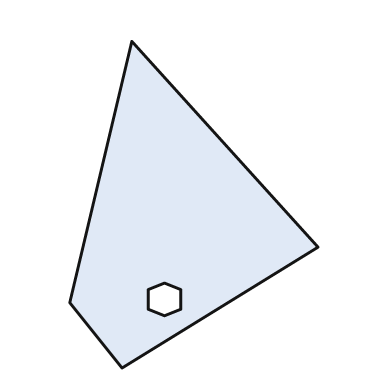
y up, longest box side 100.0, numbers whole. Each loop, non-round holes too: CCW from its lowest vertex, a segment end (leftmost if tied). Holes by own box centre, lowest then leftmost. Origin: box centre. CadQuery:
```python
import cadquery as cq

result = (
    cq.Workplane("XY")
    .moveTo(-22.0, -50.0)
    .lineTo(38.0, -13.0)
    .lineTo(-19.0, 50.0)
    .lineTo(-38.0, -30.0)
    .close()
    .moveTo(-9.0, -34.0)
    .lineTo(-4.0, -32.0)
    .lineTo(-4.0, -26.0)
    .lineTo(-9.0, -24.0)
    .lineTo(-14.0, -26.0)
    .lineTo(-14.0, -32.0)
    .close()
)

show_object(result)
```